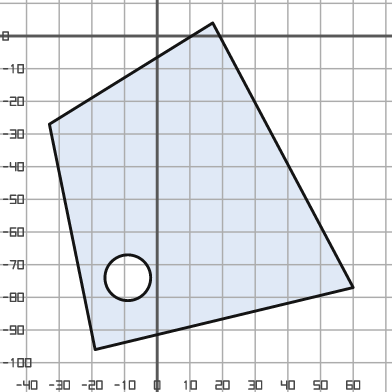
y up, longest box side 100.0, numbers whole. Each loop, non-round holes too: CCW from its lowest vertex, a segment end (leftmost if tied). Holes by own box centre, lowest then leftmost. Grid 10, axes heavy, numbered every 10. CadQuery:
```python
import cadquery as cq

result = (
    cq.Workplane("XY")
    .moveTo(-19.0, -96.0)
    .lineTo(60.0, -77.0)
    .lineTo(17.0, 4.0)
    .lineTo(-33.0, -27.0)
    .close()
    .moveTo(-9.0, -74.0)
    .circle(7.0)
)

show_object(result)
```